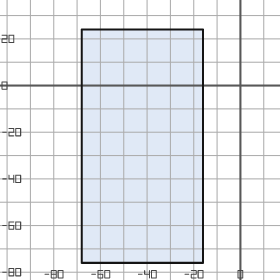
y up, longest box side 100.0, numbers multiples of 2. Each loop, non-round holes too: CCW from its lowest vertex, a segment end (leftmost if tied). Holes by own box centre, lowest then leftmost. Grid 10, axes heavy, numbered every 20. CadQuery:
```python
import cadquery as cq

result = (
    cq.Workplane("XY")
    .moveTo(-68.0, -76.0)
    .lineTo(-16.0, -76.0)
    .lineTo(-16.0, 24.0)
    .lineTo(-68.0, 24.0)
    .close()
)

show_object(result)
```